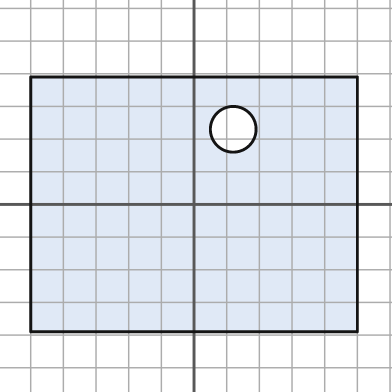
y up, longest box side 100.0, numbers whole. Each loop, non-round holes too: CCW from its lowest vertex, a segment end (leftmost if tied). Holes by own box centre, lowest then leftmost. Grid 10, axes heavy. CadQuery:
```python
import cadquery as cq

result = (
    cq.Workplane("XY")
    .moveTo(-50.0, -39.0)
    .lineTo(50.0, -39.0)
    .lineTo(50.0, 39.0)
    .lineTo(-50.0, 39.0)
    .close()
    .moveTo(12.0, 23.0)
    .circle(7.0)
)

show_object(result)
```